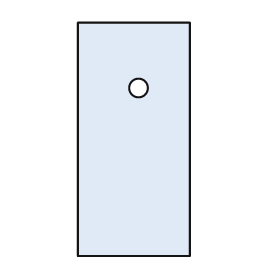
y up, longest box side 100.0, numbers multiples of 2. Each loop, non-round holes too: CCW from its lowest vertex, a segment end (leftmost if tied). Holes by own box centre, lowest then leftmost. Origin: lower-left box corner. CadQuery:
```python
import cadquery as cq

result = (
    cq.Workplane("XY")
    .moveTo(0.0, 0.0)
    .lineTo(48.0, 0.0)
    .lineTo(48.0, 100.0)
    .lineTo(0.0, 100.0)
    .close()
    .moveTo(26.0, 72.0)
    .circle(4.0)
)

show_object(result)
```